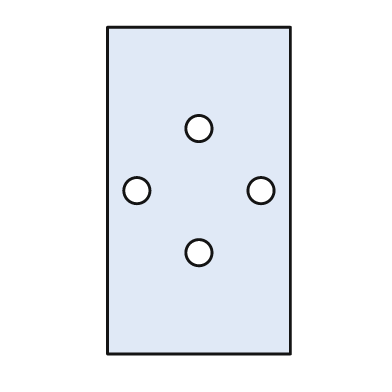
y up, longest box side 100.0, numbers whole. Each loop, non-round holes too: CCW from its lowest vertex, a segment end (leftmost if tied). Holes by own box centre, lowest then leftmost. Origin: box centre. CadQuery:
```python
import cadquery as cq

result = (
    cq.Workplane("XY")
    .moveTo(-28.0, -50.0)
    .lineTo(28.0, -50.0)
    .lineTo(28.0, 50.0)
    .lineTo(-28.0, 50.0)
    .close()
    .moveTo(0.0, -19.0)
    .circle(4.0)
    .moveTo(-19.0, 0.0)
    .circle(4.0)
    .moveTo(19.0, 0.0)
    .circle(4.0)
    .moveTo(0.0, 19.0)
    .circle(4.0)
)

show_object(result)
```